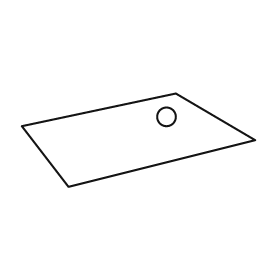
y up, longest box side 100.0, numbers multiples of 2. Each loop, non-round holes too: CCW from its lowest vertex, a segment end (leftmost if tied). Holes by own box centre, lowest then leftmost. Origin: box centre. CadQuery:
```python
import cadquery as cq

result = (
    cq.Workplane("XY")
    .moveTo(-30.0, -20.0)
    .lineTo(50.0, 0.0)
    .lineTo(16.0, 20.0)
    .lineTo(-50.0, 6.0)
    .close()
    .moveTo(12.0, 10.0)
    .circle(4.0)
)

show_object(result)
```